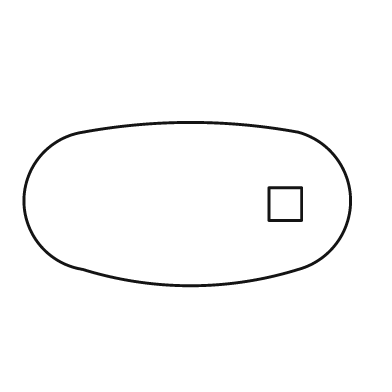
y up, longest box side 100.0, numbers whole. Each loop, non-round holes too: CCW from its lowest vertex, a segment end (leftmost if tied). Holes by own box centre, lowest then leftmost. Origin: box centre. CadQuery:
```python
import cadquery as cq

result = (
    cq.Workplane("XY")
    .moveTo(-32.0, -20.0)
    .threePointArc((1.0, -25.0), (34.0, -20.0))
    .threePointArc((50.0, 1.0), (34.0, 22.0))
    .threePointArc((1.0, 25.0), (-32.0, 22.0))
    .threePointArc((-50.0, 1.0), (-32.0, -20.0))
    .close()
    .moveTo(25.0, -5.0)
    .lineTo(35.0, -5.0)
    .lineTo(35.0, 5.0)
    .lineTo(25.0, 5.0)
    .close()
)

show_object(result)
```